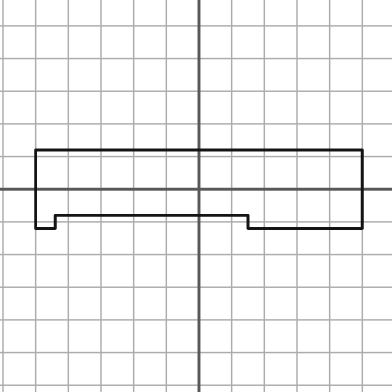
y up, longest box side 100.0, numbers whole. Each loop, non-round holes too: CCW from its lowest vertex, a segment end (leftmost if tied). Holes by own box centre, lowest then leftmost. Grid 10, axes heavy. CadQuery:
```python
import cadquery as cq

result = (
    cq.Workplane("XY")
    .moveTo(-50.0, -12.0)
    .lineTo(-44.0, -12.0)
    .lineTo(-44.0, -8.0)
    .lineTo(15.0, -8.0)
    .lineTo(15.0, -12.0)
    .lineTo(50.0, -12.0)
    .lineTo(50.0, 12.0)
    .lineTo(-50.0, 12.0)
    .close()
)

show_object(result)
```